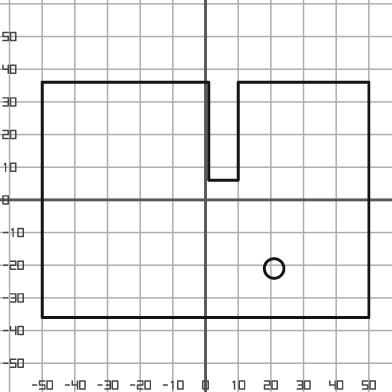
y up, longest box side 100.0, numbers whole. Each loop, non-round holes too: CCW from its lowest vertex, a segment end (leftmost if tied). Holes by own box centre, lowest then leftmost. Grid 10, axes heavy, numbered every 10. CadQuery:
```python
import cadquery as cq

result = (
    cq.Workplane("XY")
    .moveTo(-50.0, -36.0)
    .lineTo(50.0, -36.0)
    .lineTo(50.0, 36.0)
    .lineTo(10.0, 36.0)
    .lineTo(10.0, 6.0)
    .lineTo(1.0, 6.0)
    .lineTo(1.0, 36.0)
    .lineTo(-50.0, 36.0)
    .close()
    .moveTo(21.0, -21.0)
    .circle(3.0)
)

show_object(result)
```